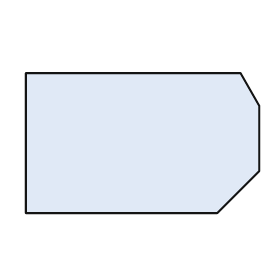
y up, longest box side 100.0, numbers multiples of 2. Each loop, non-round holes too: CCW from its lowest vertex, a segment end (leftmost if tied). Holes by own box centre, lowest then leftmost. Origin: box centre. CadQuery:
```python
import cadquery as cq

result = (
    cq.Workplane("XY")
    .moveTo(-50.0, -30.0)
    .lineTo(32.0, -30.0)
    .lineTo(50.0, -12.0)
    .lineTo(50.0, 16.0)
    .lineTo(42.0, 30.0)
    .lineTo(-50.0, 30.0)
    .close()
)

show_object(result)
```